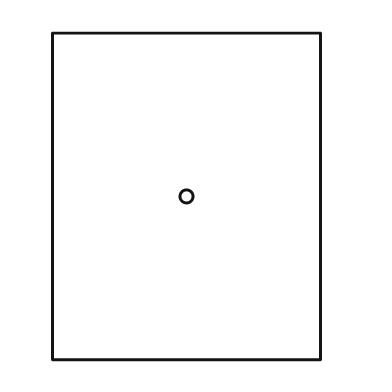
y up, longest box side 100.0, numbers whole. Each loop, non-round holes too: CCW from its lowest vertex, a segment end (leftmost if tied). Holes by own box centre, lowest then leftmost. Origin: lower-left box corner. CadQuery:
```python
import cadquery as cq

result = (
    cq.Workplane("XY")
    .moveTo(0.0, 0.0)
    .lineTo(82.0, 0.0)
    .lineTo(82.0, 100.0)
    .lineTo(0.0, 100.0)
    .close()
    .moveTo(41.0, 50.0)
    .circle(2.0)
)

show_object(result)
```